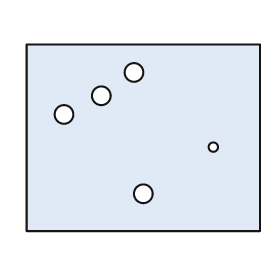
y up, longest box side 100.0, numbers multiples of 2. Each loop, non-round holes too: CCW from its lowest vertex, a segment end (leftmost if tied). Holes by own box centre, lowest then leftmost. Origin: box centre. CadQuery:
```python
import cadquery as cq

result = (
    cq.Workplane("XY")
    .moveTo(-50.0, -40.0)
    .lineTo(50.0, -40.0)
    .lineTo(50.0, 40.0)
    .lineTo(-50.0, 40.0)
    .close()
    .moveTo(0.0, -24.0)
    .circle(4.0)
    .moveTo(30.0, -4.0)
    .circle(2.0)
    .moveTo(-34.0, 10.0)
    .circle(4.0)
    .moveTo(-18.0, 18.0)
    .circle(4.0)
    .moveTo(-4.0, 28.0)
    .circle(4.0)
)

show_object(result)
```